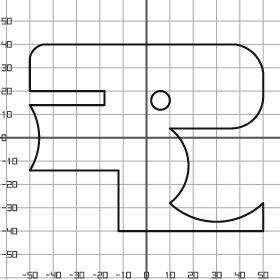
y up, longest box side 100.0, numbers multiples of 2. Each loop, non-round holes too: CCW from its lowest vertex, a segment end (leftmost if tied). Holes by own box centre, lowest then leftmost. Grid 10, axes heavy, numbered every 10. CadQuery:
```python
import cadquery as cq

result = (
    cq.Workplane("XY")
    .moveTo(-12.0, -40.0)
    .lineTo(50.0, -40.0)
    .lineTo(50.0, -28.0)
    .threePointArc((30.0, -36.0), (10.0, -28.0))
    .threePointArc((18.0, -12.0), (10.0, 4.0))
    .lineTo(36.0, 4.0)
    .threePointArc((46.0, 8.0), (50.0, 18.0))
    .lineTo(50.0, 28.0)
    .threePointArc((46.0, 36.0), (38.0, 40.0))
    .lineTo(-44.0, 40.0)
    .threePointArc((-48.0, 38.0), (-50.0, 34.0))
    .lineTo(-50.0, 20.0)
    .lineTo(-18.0, 20.0)
    .lineTo(-18.0, 14.0)
    .lineTo(-50.0, 14.0)
    .threePointArc((-46.0, 0.0), (-50.0, -14.0))
    .lineTo(-12.0, -14.0)
    .close()
    .moveTo(6.0, 16.0)
    .circle(4.0)
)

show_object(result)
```